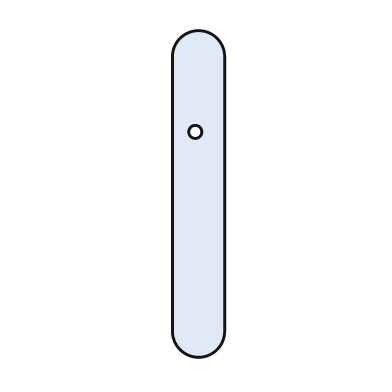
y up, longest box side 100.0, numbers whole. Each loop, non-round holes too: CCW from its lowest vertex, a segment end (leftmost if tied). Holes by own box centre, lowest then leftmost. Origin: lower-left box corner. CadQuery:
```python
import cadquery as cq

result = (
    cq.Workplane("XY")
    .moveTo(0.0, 8.0)
    .threePointArc((8.0, 0.0), (16.0, 8.0))
    .lineTo(16.0, 92.0)
    .threePointArc((8.0, 100.0), (0.0, 92.0))
    .close()
    .moveTo(7.0, 69.0)
    .circle(2.0)
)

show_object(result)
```